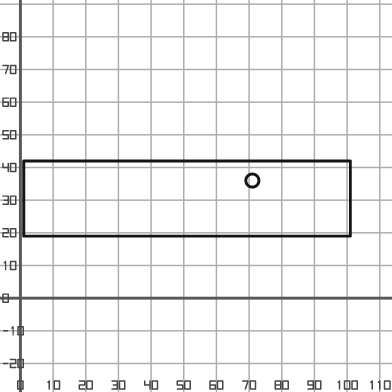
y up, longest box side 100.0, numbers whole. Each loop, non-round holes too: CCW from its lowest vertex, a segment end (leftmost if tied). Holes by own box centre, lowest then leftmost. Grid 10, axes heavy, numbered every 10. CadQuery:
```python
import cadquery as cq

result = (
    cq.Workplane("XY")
    .moveTo(1.0, 19.0)
    .lineTo(101.0, 19.0)
    .lineTo(101.0, 42.0)
    .lineTo(1.0, 42.0)
    .close()
    .moveTo(71.0, 36.0)
    .circle(2.0)
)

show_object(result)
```